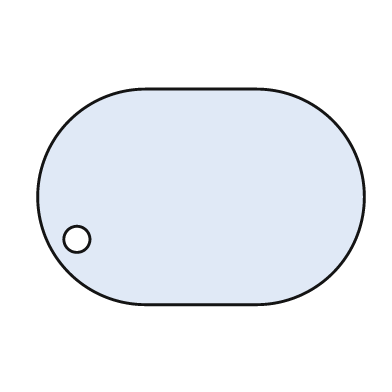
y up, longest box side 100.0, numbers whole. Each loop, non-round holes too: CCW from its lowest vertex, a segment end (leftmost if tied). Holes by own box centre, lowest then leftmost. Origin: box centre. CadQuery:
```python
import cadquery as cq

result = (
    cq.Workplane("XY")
    .moveTo(-17.0, -33.0)
    .lineTo(17.0, -33.0)
    .threePointArc((50.0, 0.0), (17.0, 33.0))
    .lineTo(-17.0, 33.0)
    .threePointArc((-50.0, 0.0), (-17.0, -33.0))
    .close()
    .moveTo(-38.0, -13.0)
    .circle(4.0)
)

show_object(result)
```